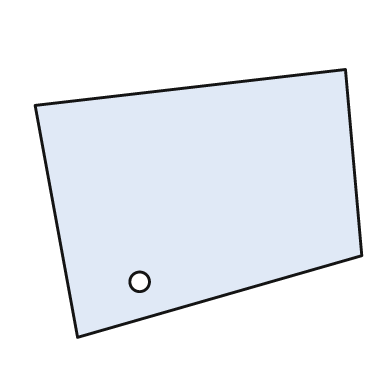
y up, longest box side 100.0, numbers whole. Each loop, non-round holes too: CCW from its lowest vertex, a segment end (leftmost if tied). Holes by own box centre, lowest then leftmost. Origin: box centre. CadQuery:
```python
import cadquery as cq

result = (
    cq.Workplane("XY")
    .moveTo(-37.0, -41.0)
    .lineTo(50.0, -16.0)
    .lineTo(45.0, 41.0)
    .lineTo(-50.0, 30.0)
    .close()
    .moveTo(-18.0, -24.0)
    .circle(3.0)
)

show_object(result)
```